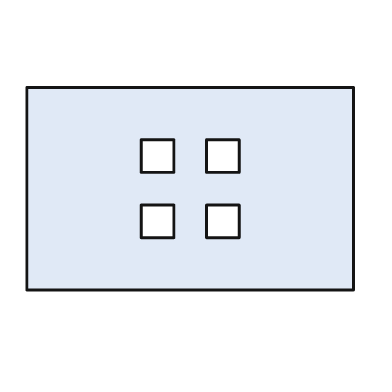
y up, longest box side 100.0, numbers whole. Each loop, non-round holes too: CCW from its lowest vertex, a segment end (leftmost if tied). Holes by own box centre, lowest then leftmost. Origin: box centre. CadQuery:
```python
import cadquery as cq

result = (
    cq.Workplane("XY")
    .moveTo(-50.0, -31.0)
    .lineTo(50.0, -31.0)
    .lineTo(50.0, 31.0)
    .lineTo(-50.0, 31.0)
    .close()
    .moveTo(-15.0, -15.0)
    .lineTo(-5.0, -15.0)
    .lineTo(-5.0, -5.0)
    .lineTo(-15.0, -5.0)
    .close()
    .moveTo(5.0, -15.0)
    .lineTo(15.0, -15.0)
    .lineTo(15.0, -5.0)
    .lineTo(5.0, -5.0)
    .close()
    .moveTo(-15.0, 5.0)
    .lineTo(-5.0, 5.0)
    .lineTo(-5.0, 15.0)
    .lineTo(-15.0, 15.0)
    .close()
    .moveTo(5.0, 5.0)
    .lineTo(15.0, 5.0)
    .lineTo(15.0, 15.0)
    .lineTo(5.0, 15.0)
    .close()
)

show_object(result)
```